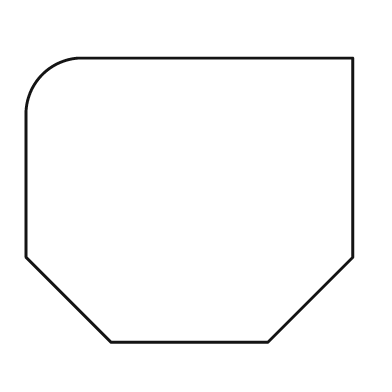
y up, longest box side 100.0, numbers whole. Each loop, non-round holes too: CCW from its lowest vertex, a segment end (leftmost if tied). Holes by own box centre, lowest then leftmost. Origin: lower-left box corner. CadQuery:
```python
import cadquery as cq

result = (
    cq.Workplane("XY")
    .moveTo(26.0, 0.0)
    .lineTo(74.0, 0.0)
    .lineTo(100.0, 26.0)
    .lineTo(100.0, 87.0)
    .lineTo(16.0, 87.0)
    .threePointArc((5.0, 82.0), (0.0, 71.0))
    .lineTo(0.0, 26.0)
    .close()
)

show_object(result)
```